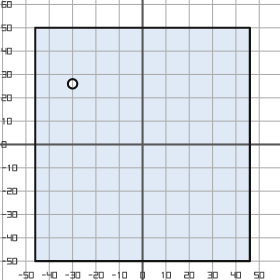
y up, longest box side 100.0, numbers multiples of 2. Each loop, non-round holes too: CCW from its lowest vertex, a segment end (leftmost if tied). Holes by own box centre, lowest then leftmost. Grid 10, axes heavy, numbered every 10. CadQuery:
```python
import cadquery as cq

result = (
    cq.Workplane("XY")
    .moveTo(-46.0, -50.0)
    .lineTo(46.0, -50.0)
    .lineTo(46.0, 50.0)
    .lineTo(-46.0, 50.0)
    .close()
    .moveTo(-30.0, 26.0)
    .circle(2.0)
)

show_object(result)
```